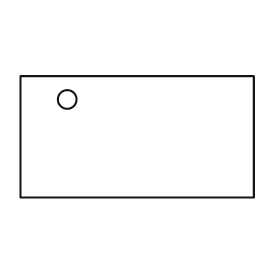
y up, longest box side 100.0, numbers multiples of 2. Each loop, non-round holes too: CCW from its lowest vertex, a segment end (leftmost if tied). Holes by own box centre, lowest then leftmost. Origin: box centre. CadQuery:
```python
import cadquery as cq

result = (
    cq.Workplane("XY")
    .moveTo(-50.0, -26.0)
    .lineTo(50.0, -26.0)
    .lineTo(50.0, 26.0)
    .lineTo(-50.0, 26.0)
    .close()
    .moveTo(-30.0, 16.0)
    .circle(4.0)
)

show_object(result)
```